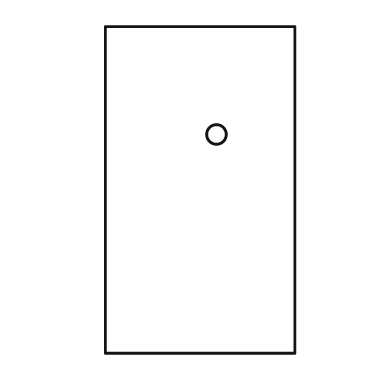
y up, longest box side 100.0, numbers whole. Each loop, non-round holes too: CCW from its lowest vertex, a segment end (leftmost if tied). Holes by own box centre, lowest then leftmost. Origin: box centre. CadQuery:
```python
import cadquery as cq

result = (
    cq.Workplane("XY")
    .moveTo(-29.0, -50.0)
    .lineTo(29.0, -50.0)
    .lineTo(29.0, 50.0)
    .lineTo(-29.0, 50.0)
    .close()
    .moveTo(5.0, 17.0)
    .circle(3.0)
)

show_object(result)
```